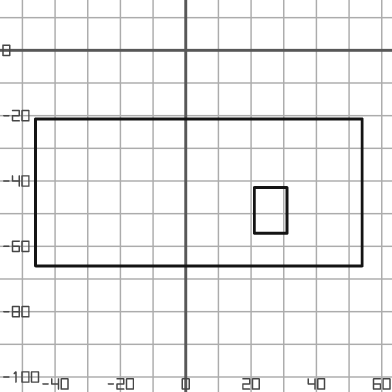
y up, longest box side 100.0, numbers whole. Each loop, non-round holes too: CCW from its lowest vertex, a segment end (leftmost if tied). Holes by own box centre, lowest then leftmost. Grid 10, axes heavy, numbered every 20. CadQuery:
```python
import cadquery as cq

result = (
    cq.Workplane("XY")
    .moveTo(-46.0, -66.0)
    .lineTo(54.0, -66.0)
    .lineTo(54.0, -21.0)
    .lineTo(-46.0, -21.0)
    .close()
    .moveTo(21.0, -56.0)
    .lineTo(31.0, -56.0)
    .lineTo(31.0, -42.0)
    .lineTo(21.0, -42.0)
    .close()
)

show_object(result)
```